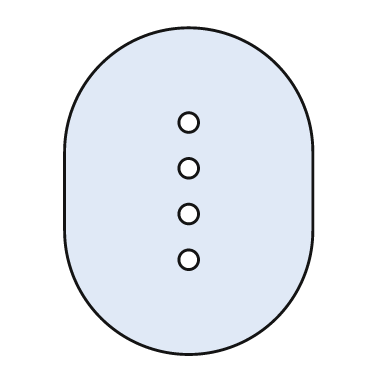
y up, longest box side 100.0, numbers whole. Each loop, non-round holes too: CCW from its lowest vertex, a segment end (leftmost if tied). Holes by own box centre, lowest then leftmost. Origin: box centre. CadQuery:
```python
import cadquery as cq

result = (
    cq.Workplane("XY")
    .moveTo(-38.0, -12.0)
    .threePointArc((0.0, -50.0), (38.0, -12.0))
    .lineTo(38.0, 12.0)
    .threePointArc((0.0, 50.0), (-38.0, 12.0))
    .close()
    .moveTo(0.0, -21.0)
    .circle(3.0)
    .moveTo(0.0, -7.0)
    .circle(3.0)
    .moveTo(0.0, 7.0)
    .circle(3.0)
    .moveTo(0.0, 21.0)
    .circle(3.0)
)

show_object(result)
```